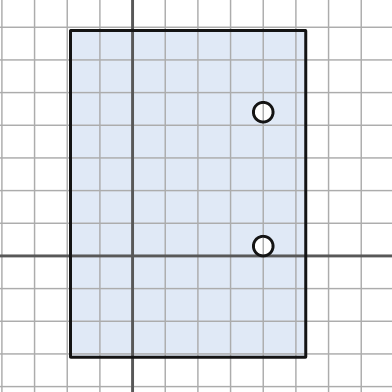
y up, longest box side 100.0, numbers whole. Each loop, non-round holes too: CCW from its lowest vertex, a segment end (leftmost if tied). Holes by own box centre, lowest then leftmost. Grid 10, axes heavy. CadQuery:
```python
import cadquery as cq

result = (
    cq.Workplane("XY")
    .moveTo(-19.0, -31.0)
    .lineTo(53.0, -31.0)
    .lineTo(53.0, 69.0)
    .lineTo(-19.0, 69.0)
    .close()
    .moveTo(40.0, 3.0)
    .circle(3.0)
    .moveTo(40.0, 44.0)
    .circle(3.0)
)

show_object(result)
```